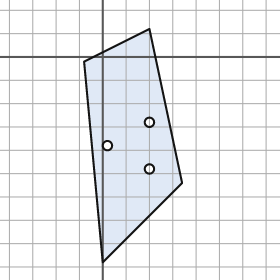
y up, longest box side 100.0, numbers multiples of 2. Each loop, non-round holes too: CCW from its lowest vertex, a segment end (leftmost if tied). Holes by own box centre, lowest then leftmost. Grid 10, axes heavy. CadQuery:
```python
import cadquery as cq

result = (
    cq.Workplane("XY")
    .moveTo(0.0, -88.0)
    .lineTo(34.0, -54.0)
    .lineTo(20.0, 12.0)
    .lineTo(-8.0, -2.0)
    .close()
    .moveTo(20.0, -48.0)
    .circle(2.0)
    .moveTo(2.0, -38.0)
    .circle(2.0)
    .moveTo(20.0, -28.0)
    .circle(2.0)
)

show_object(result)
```